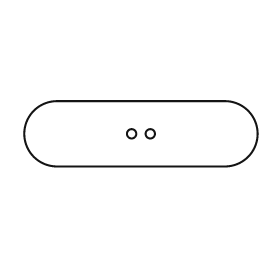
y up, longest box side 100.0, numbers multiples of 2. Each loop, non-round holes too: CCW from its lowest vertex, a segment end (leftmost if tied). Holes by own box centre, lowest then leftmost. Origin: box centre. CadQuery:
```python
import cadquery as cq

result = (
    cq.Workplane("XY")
    .moveTo(-36.0, -14.0)
    .lineTo(36.0, -14.0)
    .threePointArc((50.0, 0.0), (36.0, 14.0))
    .lineTo(-36.0, 14.0)
    .threePointArc((-50.0, 0.0), (-36.0, -14.0))
    .close()
    .moveTo(-4.0, 0.0)
    .circle(2.0)
    .moveTo(4.0, 0.0)
    .circle(2.0)
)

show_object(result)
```